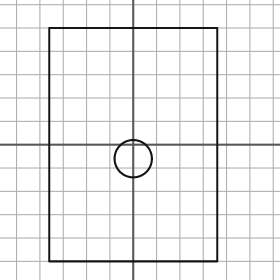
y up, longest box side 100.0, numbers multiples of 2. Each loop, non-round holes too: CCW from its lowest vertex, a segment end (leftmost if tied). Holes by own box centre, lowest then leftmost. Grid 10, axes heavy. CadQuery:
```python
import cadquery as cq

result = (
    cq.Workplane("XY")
    .moveTo(-36.0, -50.0)
    .lineTo(36.0, -50.0)
    .lineTo(36.0, 50.0)
    .lineTo(-36.0, 50.0)
    .close()
    .moveTo(0.0, -6.0)
    .circle(8.0)
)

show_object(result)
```